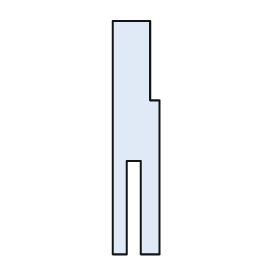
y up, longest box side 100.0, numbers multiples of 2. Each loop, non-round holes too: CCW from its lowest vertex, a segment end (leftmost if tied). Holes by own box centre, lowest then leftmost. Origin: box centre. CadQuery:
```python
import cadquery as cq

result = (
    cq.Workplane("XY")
    .moveTo(-10.0, -50.0)
    .lineTo(-4.0, -50.0)
    .lineTo(-4.0, -10.0)
    .lineTo(2.0, -10.0)
    .lineTo(2.0, -50.0)
    .lineTo(10.0, -50.0)
    .lineTo(10.0, 16.0)
    .lineTo(6.0, 16.0)
    .lineTo(6.0, 50.0)
    .lineTo(-10.0, 50.0)
    .close()
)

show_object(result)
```